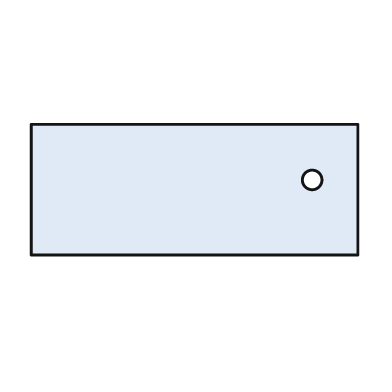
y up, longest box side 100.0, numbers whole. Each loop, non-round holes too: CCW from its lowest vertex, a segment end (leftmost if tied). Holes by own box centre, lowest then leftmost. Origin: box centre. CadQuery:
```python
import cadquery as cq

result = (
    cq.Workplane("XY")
    .moveTo(-50.0, -20.0)
    .lineTo(50.0, -20.0)
    .lineTo(50.0, 20.0)
    .lineTo(-50.0, 20.0)
    .close()
    .moveTo(36.0, 3.0)
    .circle(3.0)
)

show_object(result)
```